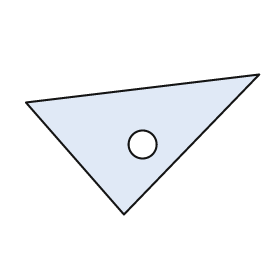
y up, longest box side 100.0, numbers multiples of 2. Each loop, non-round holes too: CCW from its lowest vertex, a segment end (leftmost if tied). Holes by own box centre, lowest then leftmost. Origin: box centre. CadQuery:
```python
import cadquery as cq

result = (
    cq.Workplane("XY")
    .moveTo(-8.0, -30.0)
    .lineTo(50.0, 30.0)
    .lineTo(-50.0, 18.0)
    .close()
    .moveTo(0.0, 0.0)
    .circle(6.0)
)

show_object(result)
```